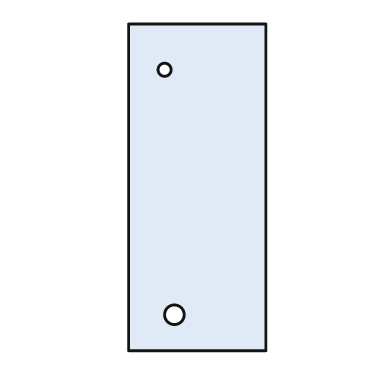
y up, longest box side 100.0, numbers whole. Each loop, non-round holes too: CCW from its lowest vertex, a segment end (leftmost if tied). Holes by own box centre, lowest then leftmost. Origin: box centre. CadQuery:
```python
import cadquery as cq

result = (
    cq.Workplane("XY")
    .moveTo(-21.0, -50.0)
    .lineTo(21.0, -50.0)
    .lineTo(21.0, 50.0)
    .lineTo(-21.0, 50.0)
    .close()
    .moveTo(-7.0, -39.0)
    .circle(3.0)
    .moveTo(-10.0, 36.0)
    .circle(2.0)
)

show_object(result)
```